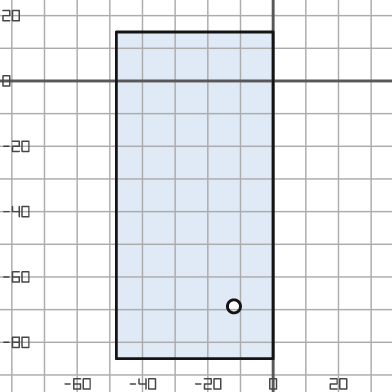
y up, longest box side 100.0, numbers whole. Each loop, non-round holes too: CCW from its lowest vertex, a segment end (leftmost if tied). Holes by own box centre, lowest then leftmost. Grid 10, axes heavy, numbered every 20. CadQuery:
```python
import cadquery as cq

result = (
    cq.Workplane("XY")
    .moveTo(-48.0, -85.0)
    .lineTo(0.0, -85.0)
    .lineTo(0.0, 15.0)
    .lineTo(-48.0, 15.0)
    .close()
    .moveTo(-12.0, -69.0)
    .circle(2.0)
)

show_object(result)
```